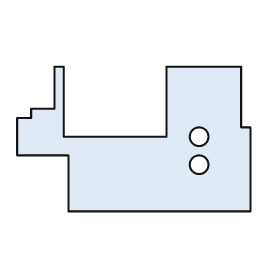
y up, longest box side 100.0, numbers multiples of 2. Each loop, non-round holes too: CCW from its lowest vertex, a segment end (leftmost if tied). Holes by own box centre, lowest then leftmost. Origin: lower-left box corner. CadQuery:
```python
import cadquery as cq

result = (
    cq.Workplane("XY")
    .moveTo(22.0, 0.0)
    .lineTo(100.0, 0.0)
    .lineTo(100.0, 36.0)
    .lineTo(96.0, 36.0)
    .lineTo(96.0, 62.0)
    .lineTo(64.0, 62.0)
    .lineTo(64.0, 32.0)
    .lineTo(20.0, 32.0)
    .lineTo(20.0, 62.0)
    .lineTo(16.0, 62.0)
    .lineTo(16.0, 44.0)
    .lineTo(6.0, 44.0)
    .lineTo(6.0, 40.0)
    .lineTo(0.0, 40.0)
    .lineTo(0.0, 24.0)
    .lineTo(22.0, 24.0)
    .close()
    .moveTo(78.0, 20.0)
    .circle(4.0)
    .moveTo(78.0, 32.0)
    .circle(4.0)
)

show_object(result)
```